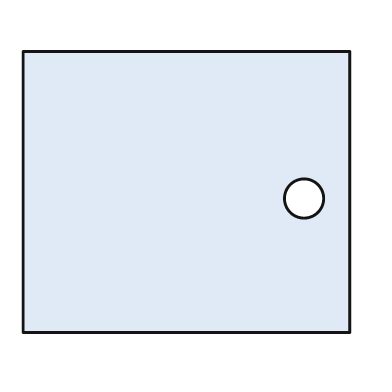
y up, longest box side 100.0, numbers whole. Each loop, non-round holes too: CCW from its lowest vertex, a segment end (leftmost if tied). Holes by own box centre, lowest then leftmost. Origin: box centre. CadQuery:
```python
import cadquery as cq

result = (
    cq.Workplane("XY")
    .moveTo(-50.0, -43.0)
    .lineTo(50.0, -43.0)
    .lineTo(50.0, 43.0)
    .lineTo(-50.0, 43.0)
    .close()
    .moveTo(36.0, -2.0)
    .circle(6.0)
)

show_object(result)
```